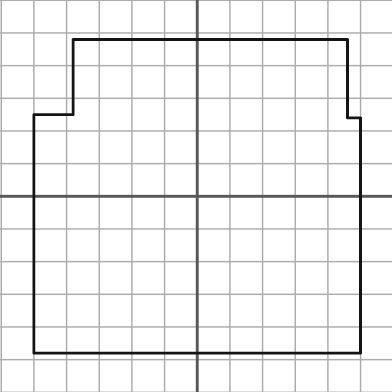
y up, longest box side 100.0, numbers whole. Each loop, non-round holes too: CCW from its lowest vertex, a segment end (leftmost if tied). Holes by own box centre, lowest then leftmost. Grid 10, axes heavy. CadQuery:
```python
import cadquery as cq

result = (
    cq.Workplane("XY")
    .moveTo(-50.0, -48.0)
    .lineTo(50.0, -48.0)
    .lineTo(50.0, 24.0)
    .lineTo(46.0, 24.0)
    .lineTo(46.0, 48.0)
    .lineTo(-38.0, 48.0)
    .lineTo(-38.0, 25.0)
    .lineTo(-50.0, 25.0)
    .close()
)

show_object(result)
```